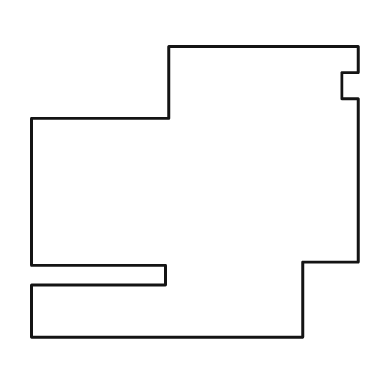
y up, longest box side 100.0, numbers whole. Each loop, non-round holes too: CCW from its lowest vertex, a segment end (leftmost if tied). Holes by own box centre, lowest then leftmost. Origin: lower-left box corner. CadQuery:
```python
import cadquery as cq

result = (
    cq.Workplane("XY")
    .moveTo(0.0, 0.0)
    .lineTo(83.0, 0.0)
    .lineTo(83.0, 23.0)
    .lineTo(100.0, 23.0)
    .lineTo(100.0, 73.0)
    .lineTo(95.0, 73.0)
    .lineTo(95.0, 81.0)
    .lineTo(100.0, 81.0)
    .lineTo(100.0, 89.0)
    .lineTo(42.0, 89.0)
    .lineTo(42.0, 67.0)
    .lineTo(0.0, 67.0)
    .lineTo(0.0, 22.0)
    .lineTo(41.0, 22.0)
    .lineTo(41.0, 16.0)
    .lineTo(0.0, 16.0)
    .close()
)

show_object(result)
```